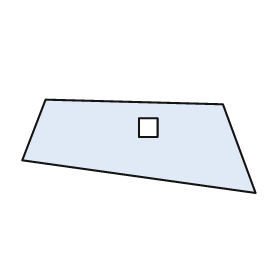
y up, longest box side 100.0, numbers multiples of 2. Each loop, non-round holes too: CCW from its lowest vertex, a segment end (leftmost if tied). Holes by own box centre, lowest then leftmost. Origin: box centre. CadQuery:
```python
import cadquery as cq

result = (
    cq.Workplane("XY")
    .moveTo(50.0, -20.0)
    .lineTo(36.0, 18.0)
    .lineTo(-40.0, 20.0)
    .lineTo(-50.0, -6.0)
    .close()
    .moveTo(0.0, 4.0)
    .lineTo(8.0, 4.0)
    .lineTo(8.0, 12.0)
    .lineTo(0.0, 12.0)
    .close()
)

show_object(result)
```